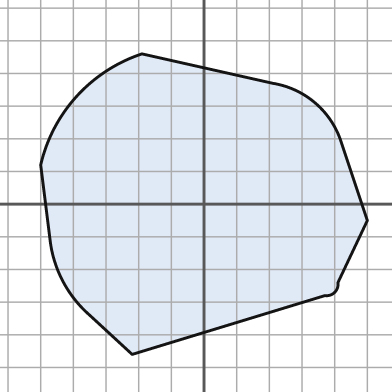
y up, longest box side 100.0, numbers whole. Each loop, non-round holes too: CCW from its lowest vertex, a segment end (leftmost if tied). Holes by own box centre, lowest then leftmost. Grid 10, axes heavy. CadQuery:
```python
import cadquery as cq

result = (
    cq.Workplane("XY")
    .moveTo(-22.0, -46.0)
    .lineTo(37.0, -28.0)
    .threePointArc((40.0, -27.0), (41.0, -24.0))
    .lineTo(50.0, -5.0)
    .lineTo(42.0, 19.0)
    .threePointArc((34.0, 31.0), (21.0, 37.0))
    .lineTo(-19.0, 46.0)
    .threePointArc((-39.0, 33.0), (-50.0, 12.0))
    .lineTo(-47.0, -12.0)
    .threePointArc((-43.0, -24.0), (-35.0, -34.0))
    .close()
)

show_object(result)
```